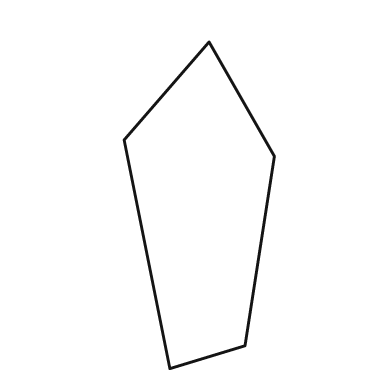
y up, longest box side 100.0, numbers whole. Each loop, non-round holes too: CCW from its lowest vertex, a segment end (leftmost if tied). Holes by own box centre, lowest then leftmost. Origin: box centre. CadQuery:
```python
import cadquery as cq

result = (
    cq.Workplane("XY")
    .moveTo(-9.0, -50.0)
    .lineTo(14.0, -43.0)
    .lineTo(23.0, 15.0)
    .lineTo(3.0, 50.0)
    .lineTo(-23.0, 20.0)
    .close()
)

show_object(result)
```